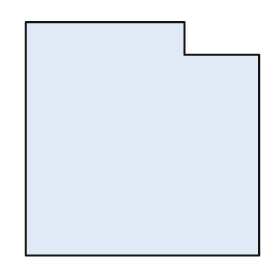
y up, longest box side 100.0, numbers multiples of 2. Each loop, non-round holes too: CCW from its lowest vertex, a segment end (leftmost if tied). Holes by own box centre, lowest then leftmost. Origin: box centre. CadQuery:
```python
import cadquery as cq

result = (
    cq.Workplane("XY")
    .moveTo(-50.0, -50.0)
    .lineTo(50.0, -50.0)
    .lineTo(50.0, 36.0)
    .lineTo(18.0, 36.0)
    .lineTo(18.0, 50.0)
    .lineTo(-50.0, 50.0)
    .close()
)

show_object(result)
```